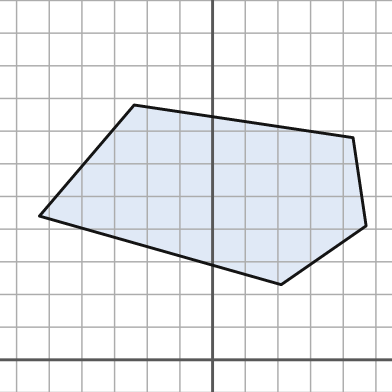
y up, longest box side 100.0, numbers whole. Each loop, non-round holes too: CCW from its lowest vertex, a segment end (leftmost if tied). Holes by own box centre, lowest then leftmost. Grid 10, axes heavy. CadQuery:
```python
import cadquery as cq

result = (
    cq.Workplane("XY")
    .moveTo(21.0, 23.0)
    .lineTo(47.0, 41.0)
    .lineTo(43.0, 68.0)
    .lineTo(-24.0, 78.0)
    .lineTo(-53.0, 44.0)
    .close()
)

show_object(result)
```